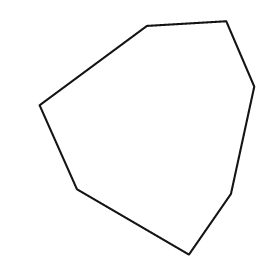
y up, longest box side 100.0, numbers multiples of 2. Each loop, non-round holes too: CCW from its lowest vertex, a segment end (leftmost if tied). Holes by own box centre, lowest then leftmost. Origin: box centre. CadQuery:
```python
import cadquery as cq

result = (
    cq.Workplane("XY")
    .moveTo(18.0, -50.0)
    .lineTo(36.0, -24.0)
    .lineTo(46.0, 22.0)
    .lineTo(34.0, 50.0)
    .lineTo(0.0, 48.0)
    .lineTo(-46.0, 14.0)
    .lineTo(-30.0, -22.0)
    .close()
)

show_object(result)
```